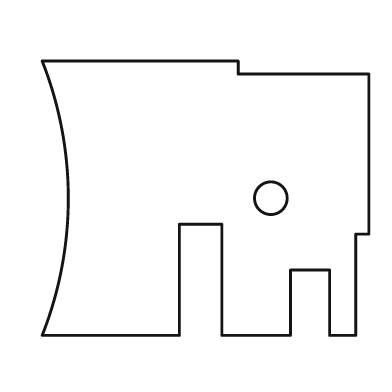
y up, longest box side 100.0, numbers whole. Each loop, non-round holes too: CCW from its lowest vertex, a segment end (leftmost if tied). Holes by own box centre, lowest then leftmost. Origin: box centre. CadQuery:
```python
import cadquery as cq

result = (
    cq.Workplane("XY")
    .moveTo(-50.0, -42.0)
    .lineTo(-8.0, -42.0)
    .lineTo(-8.0, -8.0)
    .lineTo(5.0, -8.0)
    .lineTo(5.0, -42.0)
    .lineTo(26.0, -42.0)
    .lineTo(26.0, -22.0)
    .lineTo(38.0, -22.0)
    .lineTo(38.0, -42.0)
    .lineTo(46.0, -42.0)
    .lineTo(46.0, -11.0)
    .lineTo(50.0, -11.0)
    .lineTo(50.0, 38.0)
    .lineTo(10.0, 38.0)
    .lineTo(10.0, 42.0)
    .lineTo(-50.0, 42.0)
    .threePointArc((-42.0, 0.0), (-50.0, -42.0))
    .close()
    .moveTo(20.0, 0.0)
    .circle(5.0)
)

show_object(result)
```